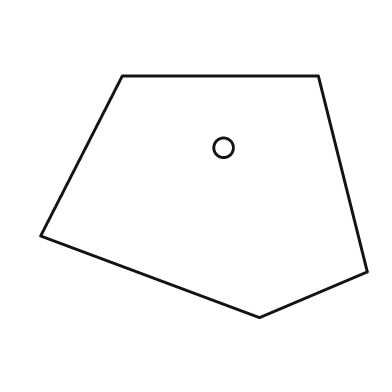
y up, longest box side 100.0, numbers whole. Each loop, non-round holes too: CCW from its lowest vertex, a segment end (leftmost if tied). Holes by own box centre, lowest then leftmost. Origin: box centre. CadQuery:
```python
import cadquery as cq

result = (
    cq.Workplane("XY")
    .moveTo(17.0, -37.0)
    .lineTo(50.0, -23.0)
    .lineTo(35.0, 37.0)
    .lineTo(-25.0, 37.0)
    .lineTo(-50.0, -12.0)
    .close()
    .moveTo(6.0, 15.0)
    .circle(3.0)
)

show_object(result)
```